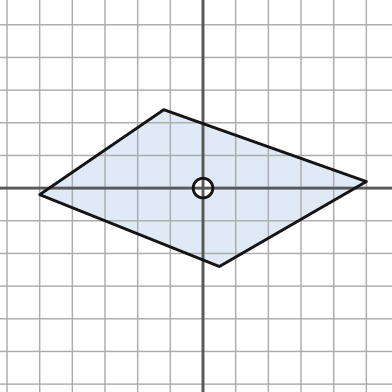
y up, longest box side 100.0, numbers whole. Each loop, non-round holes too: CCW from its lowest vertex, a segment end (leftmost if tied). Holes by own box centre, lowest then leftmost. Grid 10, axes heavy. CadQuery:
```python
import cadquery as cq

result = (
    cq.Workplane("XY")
    .moveTo(5.0, -24.0)
    .lineTo(50.0, 2.0)
    .lineTo(-12.0, 24.0)
    .lineTo(-50.0, -2.0)
    .close()
    .moveTo(0.0, 0.0)
    .circle(3.0)
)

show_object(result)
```